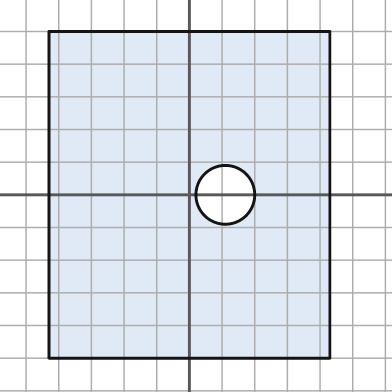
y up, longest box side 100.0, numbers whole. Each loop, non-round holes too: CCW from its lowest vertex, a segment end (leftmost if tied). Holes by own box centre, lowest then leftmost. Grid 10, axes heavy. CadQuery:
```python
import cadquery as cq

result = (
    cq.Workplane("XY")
    .moveTo(-43.0, -50.0)
    .lineTo(43.0, -50.0)
    .lineTo(43.0, 50.0)
    .lineTo(-43.0, 50.0)
    .close()
    .moveTo(11.0, 0.0)
    .circle(9.0)
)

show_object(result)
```